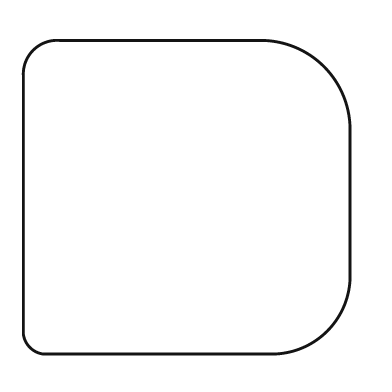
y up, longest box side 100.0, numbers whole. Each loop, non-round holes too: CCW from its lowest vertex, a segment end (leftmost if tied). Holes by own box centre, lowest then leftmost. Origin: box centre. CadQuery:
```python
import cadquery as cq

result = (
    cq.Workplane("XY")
    .moveTo(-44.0, -48.0)
    .lineTo(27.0, -48.0)
    .threePointArc((43.0, -41.0), (50.0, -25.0))
    .lineTo(50.0, 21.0)
    .threePointArc((42.0, 40.0), (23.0, 48.0))
    .lineTo(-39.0, 48.0)
    .threePointArc((-47.0, 45.0), (-50.0, 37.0))
    .lineTo(-50.0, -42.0)
    .threePointArc((-48.0, -46.0), (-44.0, -48.0))
    .close()
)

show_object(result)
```